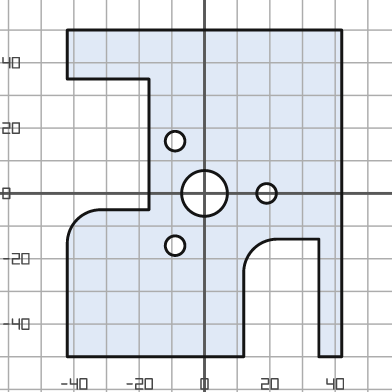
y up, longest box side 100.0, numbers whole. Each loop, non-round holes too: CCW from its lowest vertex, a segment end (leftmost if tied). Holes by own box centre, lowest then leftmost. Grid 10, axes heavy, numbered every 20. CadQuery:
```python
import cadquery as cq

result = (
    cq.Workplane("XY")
    .moveTo(-42.0, -50.0)
    .lineTo(12.0, -50.0)
    .lineTo(12.0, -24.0)
    .threePointArc((15.0, -17.0), (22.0, -14.0))
    .lineTo(35.0, -14.0)
    .lineTo(35.0, -50.0)
    .lineTo(42.0, -50.0)
    .lineTo(42.0, 50.0)
    .lineTo(-42.0, 50.0)
    .lineTo(-42.0, 35.0)
    .lineTo(-17.0, 35.0)
    .lineTo(-17.0, -5.0)
    .lineTo(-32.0, -5.0)
    .threePointArc((-39.0, -8.0), (-42.0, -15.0))
    .close()
    .moveTo(-9.0, -16.0)
    .circle(3.0)
    .moveTo(0.0, 0.0)
    .circle(7.0)
    .moveTo(19.0, 0.0)
    .circle(3.0)
    .moveTo(-9.0, 16.0)
    .circle(3.0)
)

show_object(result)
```